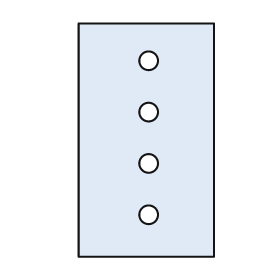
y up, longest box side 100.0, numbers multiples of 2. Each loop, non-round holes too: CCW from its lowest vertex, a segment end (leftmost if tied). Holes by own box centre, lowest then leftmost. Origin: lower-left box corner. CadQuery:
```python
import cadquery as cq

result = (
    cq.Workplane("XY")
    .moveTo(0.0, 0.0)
    .lineTo(58.0, 0.0)
    .lineTo(58.0, 100.0)
    .lineTo(0.0, 100.0)
    .close()
    .moveTo(30.0, 18.0)
    .circle(4.0)
    .moveTo(30.0, 40.0)
    .circle(4.0)
    .moveTo(30.0, 62.0)
    .circle(4.0)
    .moveTo(30.0, 84.0)
    .circle(4.0)
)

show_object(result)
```